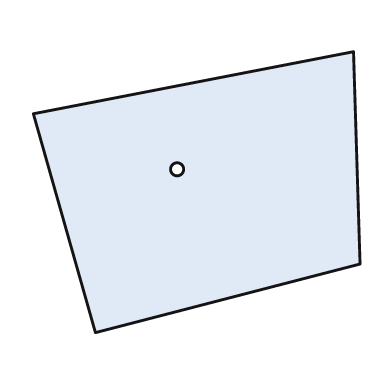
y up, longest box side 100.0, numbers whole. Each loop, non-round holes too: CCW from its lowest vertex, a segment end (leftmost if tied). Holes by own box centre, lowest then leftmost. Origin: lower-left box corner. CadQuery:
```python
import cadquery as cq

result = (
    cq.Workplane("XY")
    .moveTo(19.0, 0.0)
    .lineTo(100.0, 21.0)
    .lineTo(98.0, 86.0)
    .lineTo(0.0, 67.0)
    .close()
    .moveTo(44.0, 50.0)
    .circle(2.0)
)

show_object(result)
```